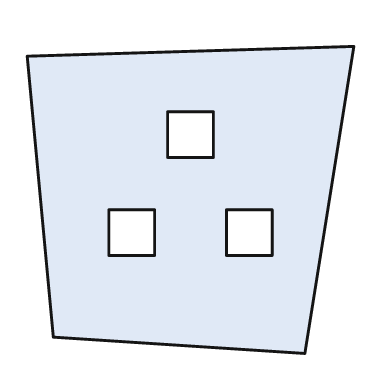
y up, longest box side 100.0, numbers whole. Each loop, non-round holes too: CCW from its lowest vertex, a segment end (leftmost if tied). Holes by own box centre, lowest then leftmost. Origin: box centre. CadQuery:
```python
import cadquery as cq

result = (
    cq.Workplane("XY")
    .moveTo(35.0, -47.0)
    .lineTo(50.0, 47.0)
    .lineTo(-50.0, 44.0)
    .lineTo(-42.0, -42.0)
    .close()
    .moveTo(-25.0, -17.0)
    .lineTo(-11.0, -17.0)
    .lineTo(-11.0, -3.0)
    .lineTo(-25.0, -3.0)
    .close()
    .moveTo(11.0, -17.0)
    .lineTo(25.0, -17.0)
    .lineTo(25.0, -3.0)
    .lineTo(11.0, -3.0)
    .close()
    .moveTo(-7.0, 13.0)
    .lineTo(7.0, 13.0)
    .lineTo(7.0, 27.0)
    .lineTo(-7.0, 27.0)
    .close()
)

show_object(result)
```